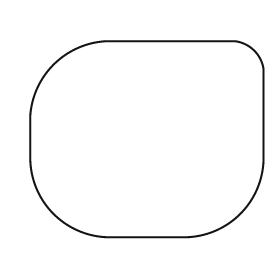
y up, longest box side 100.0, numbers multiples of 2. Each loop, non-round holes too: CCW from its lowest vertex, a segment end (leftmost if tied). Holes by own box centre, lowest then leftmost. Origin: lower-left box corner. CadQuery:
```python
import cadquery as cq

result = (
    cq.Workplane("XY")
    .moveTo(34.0, 0.0)
    .lineTo(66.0, 0.0)
    .threePointArc((90.0, 10.0), (100.0, 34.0))
    .lineTo(100.0, 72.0)
    .threePointArc((96.0, 80.0), (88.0, 84.0))
    .lineTo(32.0, 84.0)
    .threePointArc((10.0, 74.0), (0.0, 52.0))
    .lineTo(0.0, 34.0)
    .threePointArc((10.0, 10.0), (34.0, 0.0))
    .close()
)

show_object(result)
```